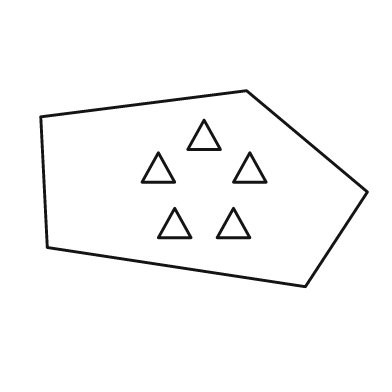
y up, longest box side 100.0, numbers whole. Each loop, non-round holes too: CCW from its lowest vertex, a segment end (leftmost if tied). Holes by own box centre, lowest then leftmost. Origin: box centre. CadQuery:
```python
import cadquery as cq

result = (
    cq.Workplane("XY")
    .moveTo(31.0, -30.0)
    .lineTo(50.0, -1.0)
    .lineTo(13.0, 30.0)
    .lineTo(-50.0, 22.0)
    .lineTo(-48.0, -18.0)
    .close()
    .moveTo(-14.0, -15.0)
    .lineTo(-4.0, -15.0)
    .lineTo(-9.0, -6.0)
    .close()
    .moveTo(4.0, -15.0)
    .lineTo(14.0, -15.0)
    .lineTo(9.0, -6.0)
    .close()
    .moveTo(-19.0, 2.0)
    .lineTo(-9.0, 2.0)
    .lineTo(-14.0, 11.0)
    .close()
    .moveTo(9.0, 2.0)
    .lineTo(19.0, 2.0)
    .lineTo(14.0, 11.0)
    .close()
    .moveTo(-5.0, 12.0)
    .lineTo(5.0, 12.0)
    .lineTo(0.0, 21.0)
    .close()
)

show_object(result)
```